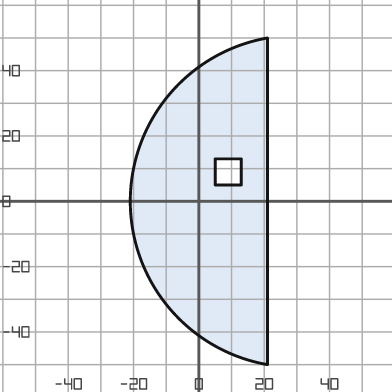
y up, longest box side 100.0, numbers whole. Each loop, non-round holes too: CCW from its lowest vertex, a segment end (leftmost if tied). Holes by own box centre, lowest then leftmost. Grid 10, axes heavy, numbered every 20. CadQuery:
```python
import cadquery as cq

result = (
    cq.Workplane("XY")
    .moveTo(21.0, -50.0)
    .lineTo(21.0, 50.0)
    .threePointArc((-21.0, 0.0), (21.0, -50.0))
    .close()
    .moveTo(5.0, 5.0)
    .lineTo(13.0, 5.0)
    .lineTo(13.0, 13.0)
    .lineTo(5.0, 13.0)
    .close()
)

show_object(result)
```